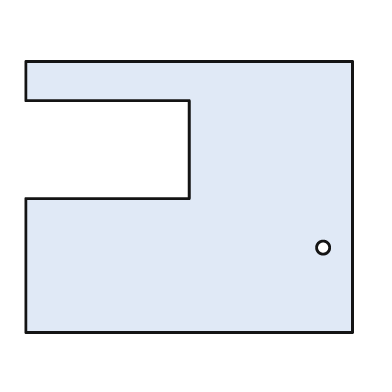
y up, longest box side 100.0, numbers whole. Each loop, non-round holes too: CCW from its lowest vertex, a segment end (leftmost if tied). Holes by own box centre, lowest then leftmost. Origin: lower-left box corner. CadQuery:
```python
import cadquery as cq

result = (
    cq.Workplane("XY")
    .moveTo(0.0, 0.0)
    .lineTo(100.0, 0.0)
    .lineTo(100.0, 83.0)
    .lineTo(0.0, 83.0)
    .lineTo(0.0, 71.0)
    .lineTo(50.0, 71.0)
    .lineTo(50.0, 41.0)
    .lineTo(0.0, 41.0)
    .close()
    .moveTo(91.0, 26.0)
    .circle(2.0)
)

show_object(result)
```